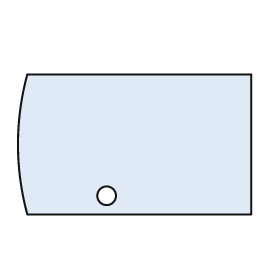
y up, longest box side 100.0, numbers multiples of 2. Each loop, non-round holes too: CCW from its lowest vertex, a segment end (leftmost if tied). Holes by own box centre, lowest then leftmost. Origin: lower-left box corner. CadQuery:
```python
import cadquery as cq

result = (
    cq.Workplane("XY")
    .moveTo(4.0, 0.0)
    .lineTo(100.0, 0.0)
    .lineTo(100.0, 60.0)
    .lineTo(4.0, 60.0)
    .threePointArc((0.0, 30.0), (4.0, 0.0))
    .close()
    .moveTo(38.0, 8.0)
    .circle(4.0)
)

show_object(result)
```